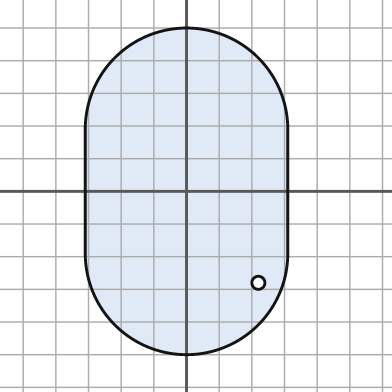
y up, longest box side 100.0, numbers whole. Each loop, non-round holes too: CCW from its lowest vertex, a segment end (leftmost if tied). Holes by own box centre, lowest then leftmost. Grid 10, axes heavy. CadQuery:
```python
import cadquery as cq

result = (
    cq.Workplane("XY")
    .moveTo(-31.0, -19.0)
    .threePointArc((0.0, -50.0), (31.0, -19.0))
    .lineTo(31.0, 19.0)
    .threePointArc((0.0, 50.0), (-31.0, 19.0))
    .close()
    .moveTo(22.0, -28.0)
    .circle(2.0)
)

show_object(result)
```